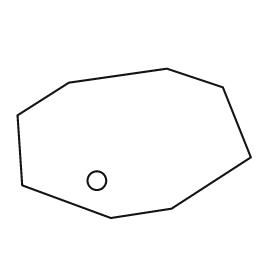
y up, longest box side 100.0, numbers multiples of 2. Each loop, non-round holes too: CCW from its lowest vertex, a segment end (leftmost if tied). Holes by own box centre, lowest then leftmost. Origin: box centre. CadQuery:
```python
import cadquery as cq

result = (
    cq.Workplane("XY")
    .moveTo(-10.0, -32.0)
    .lineTo(16.0, -28.0)
    .lineTo(50.0, -6.0)
    .lineTo(38.0, 24.0)
    .lineTo(14.0, 32.0)
    .lineTo(-28.0, 26.0)
    .lineTo(-50.0, 12.0)
    .lineTo(-48.0, -18.0)
    .close()
    .moveTo(-16.0, -16.0)
    .circle(4.0)
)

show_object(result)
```